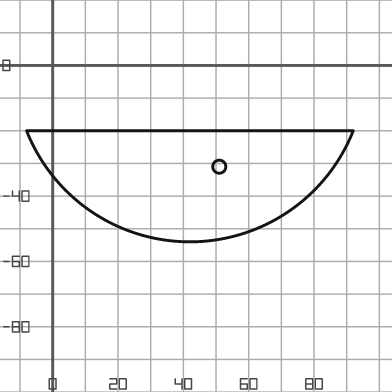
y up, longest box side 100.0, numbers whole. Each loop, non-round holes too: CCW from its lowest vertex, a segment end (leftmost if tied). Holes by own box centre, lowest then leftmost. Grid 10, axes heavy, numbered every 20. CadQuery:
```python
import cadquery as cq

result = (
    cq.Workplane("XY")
    .moveTo(-8.0, -20.0)
    .threePointArc((42.0, -54.0), (92.0, -20.0))
    .close()
    .moveTo(51.0, -31.0)
    .circle(2.0)
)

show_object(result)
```